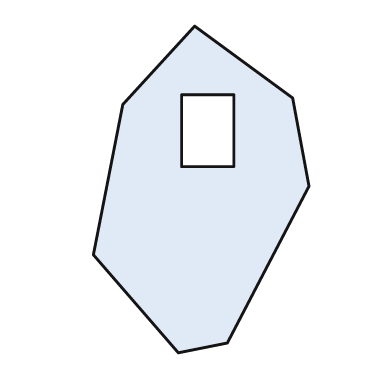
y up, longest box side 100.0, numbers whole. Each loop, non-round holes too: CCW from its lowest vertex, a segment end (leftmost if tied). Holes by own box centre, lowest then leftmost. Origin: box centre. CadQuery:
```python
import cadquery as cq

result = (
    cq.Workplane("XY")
    .moveTo(-7.0, -50.0)
    .lineTo(8.0, -47.0)
    .lineTo(33.0, 1.0)
    .lineTo(28.0, 28.0)
    .lineTo(-2.0, 50.0)
    .lineTo(-24.0, 26.0)
    .lineTo(-33.0, -20.0)
    .close()
    .moveTo(-6.0, 7.0)
    .lineTo(10.0, 7.0)
    .lineTo(10.0, 29.0)
    .lineTo(-6.0, 29.0)
    .close()
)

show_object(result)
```